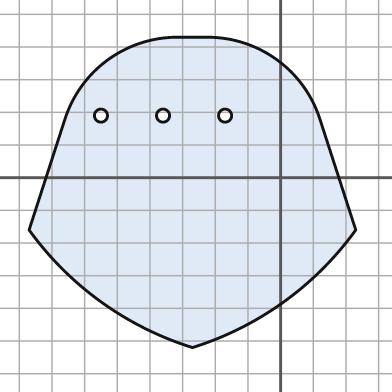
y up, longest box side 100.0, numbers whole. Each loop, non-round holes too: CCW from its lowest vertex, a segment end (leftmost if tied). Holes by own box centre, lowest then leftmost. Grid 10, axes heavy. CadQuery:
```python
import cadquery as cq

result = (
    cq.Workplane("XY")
    .moveTo(-27.0, -52.0)
    .threePointArc((1.0, -38.0), (23.0, -16.0))
    .lineTo(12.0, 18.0)
    .threePointArc((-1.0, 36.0), (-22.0, 43.0))
    .lineTo(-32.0, 43.0)
    .threePointArc((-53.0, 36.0), (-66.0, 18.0))
    .lineTo(-77.0, -16.0)
    .threePointArc((-55.0, -38.0), (-27.0, -52.0))
    .close()
    .moveTo(-55.0, 19.0)
    .circle(2.0)
    .moveTo(-36.0, 19.0)
    .circle(2.0)
    .moveTo(-17.0, 19.0)
    .circle(2.0)
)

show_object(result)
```